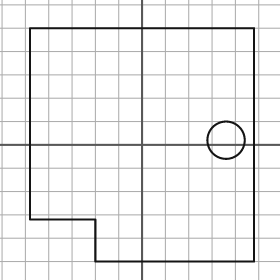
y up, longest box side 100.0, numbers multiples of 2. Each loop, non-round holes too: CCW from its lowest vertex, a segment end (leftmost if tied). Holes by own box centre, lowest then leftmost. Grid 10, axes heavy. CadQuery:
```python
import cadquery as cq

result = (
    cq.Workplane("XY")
    .moveTo(-20.0, -50.0)
    .lineTo(48.0, -50.0)
    .lineTo(48.0, 50.0)
    .lineTo(-48.0, 50.0)
    .lineTo(-48.0, -32.0)
    .lineTo(-20.0, -32.0)
    .close()
    .moveTo(36.0, 2.0)
    .circle(8.0)
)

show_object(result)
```